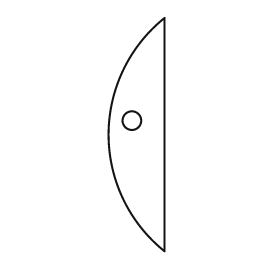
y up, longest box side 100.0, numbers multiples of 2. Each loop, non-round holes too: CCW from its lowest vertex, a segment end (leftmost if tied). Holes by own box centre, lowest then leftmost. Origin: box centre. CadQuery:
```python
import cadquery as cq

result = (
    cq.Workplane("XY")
    .moveTo(12.0, -50.0)
    .lineTo(12.0, 50.0)
    .threePointArc((-12.0, 0.0), (12.0, -50.0))
    .close()
    .moveTo(-2.0, 6.0)
    .circle(4.0)
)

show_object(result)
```